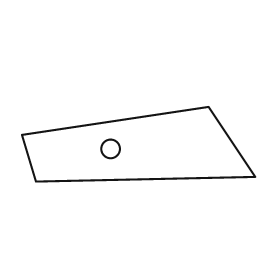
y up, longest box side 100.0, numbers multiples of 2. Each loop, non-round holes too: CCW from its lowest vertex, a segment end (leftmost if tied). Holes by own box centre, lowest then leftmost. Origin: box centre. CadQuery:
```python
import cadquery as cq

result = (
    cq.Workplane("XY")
    .moveTo(-44.0, -16.0)
    .lineTo(50.0, -14.0)
    .lineTo(30.0, 16.0)
    .lineTo(-50.0, 4.0)
    .close()
    .moveTo(-12.0, -2.0)
    .circle(4.0)
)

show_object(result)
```